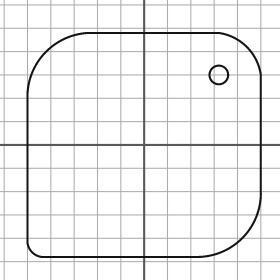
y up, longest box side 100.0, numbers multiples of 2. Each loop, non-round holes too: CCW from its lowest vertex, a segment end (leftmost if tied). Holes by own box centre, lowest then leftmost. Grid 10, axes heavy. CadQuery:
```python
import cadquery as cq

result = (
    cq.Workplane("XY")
    .moveTo(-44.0, -48.0)
    .lineTo(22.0, -48.0)
    .threePointArc((42.0, -40.0), (50.0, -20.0))
    .lineTo(50.0, 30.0)
    .threePointArc((44.0, 42.0), (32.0, 48.0))
    .lineTo(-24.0, 48.0)
    .threePointArc((-42.0, 40.0), (-50.0, 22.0))
    .lineTo(-50.0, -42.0)
    .threePointArc((-48.0, -46.0), (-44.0, -48.0))
    .close()
    .moveTo(32.0, 30.0)
    .circle(4.0)
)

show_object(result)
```